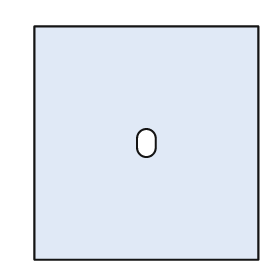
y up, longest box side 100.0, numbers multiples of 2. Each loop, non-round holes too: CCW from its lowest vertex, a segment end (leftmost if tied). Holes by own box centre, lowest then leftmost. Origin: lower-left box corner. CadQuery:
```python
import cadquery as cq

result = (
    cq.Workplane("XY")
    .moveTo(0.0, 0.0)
    .lineTo(96.0, 0.0)
    .lineTo(96.0, 100.0)
    .lineTo(0.0, 100.0)
    .close()
    .moveTo(44.0, 48.0)
    .threePointArc((48.0, 44.0), (52.0, 48.0))
    .lineTo(52.0, 52.0)
    .threePointArc((48.0, 56.0), (44.0, 52.0))
    .close()
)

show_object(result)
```